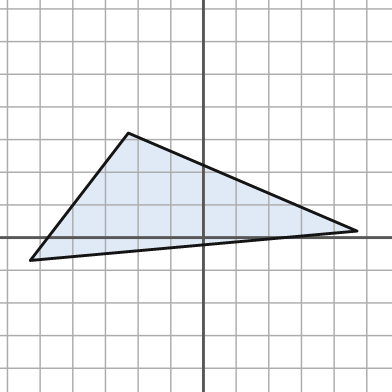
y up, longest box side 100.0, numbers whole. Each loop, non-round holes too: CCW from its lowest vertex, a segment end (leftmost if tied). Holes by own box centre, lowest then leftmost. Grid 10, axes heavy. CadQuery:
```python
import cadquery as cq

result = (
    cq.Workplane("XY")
    .moveTo(-53.0, -7.0)
    .lineTo(47.0, 2.0)
    .lineTo(-23.0, 32.0)
    .close()
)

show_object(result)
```